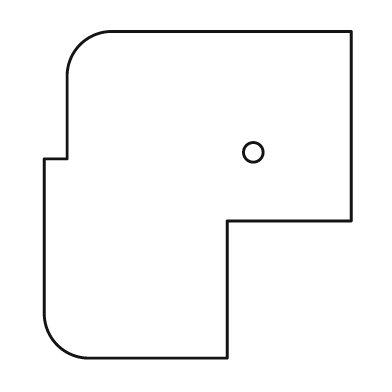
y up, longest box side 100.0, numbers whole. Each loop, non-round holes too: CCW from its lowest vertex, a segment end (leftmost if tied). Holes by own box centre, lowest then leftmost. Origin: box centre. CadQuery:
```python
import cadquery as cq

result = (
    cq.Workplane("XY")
    .moveTo(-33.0, -50.0)
    .lineTo(9.0, -50.0)
    .lineTo(9.0, -8.0)
    .lineTo(47.0, -8.0)
    .lineTo(47.0, 50.0)
    .lineTo(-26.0, 50.0)
    .threePointArc((-36.0, 46.0), (-40.0, 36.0))
    .lineTo(-40.0, 11.0)
    .lineTo(-47.0, 11.0)
    .lineTo(-47.0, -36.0)
    .threePointArc((-43.0, -46.0), (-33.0, -50.0))
    .close()
    .moveTo(17.0, 13.0)
    .circle(3.0)
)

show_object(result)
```